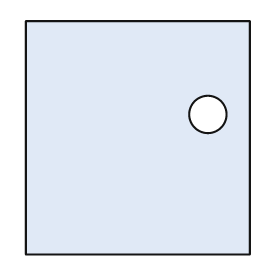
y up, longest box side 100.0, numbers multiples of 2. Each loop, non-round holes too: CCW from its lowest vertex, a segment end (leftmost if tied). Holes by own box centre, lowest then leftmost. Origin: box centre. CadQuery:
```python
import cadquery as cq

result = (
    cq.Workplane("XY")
    .moveTo(-48.0, -50.0)
    .lineTo(48.0, -50.0)
    .lineTo(48.0, 50.0)
    .lineTo(-48.0, 50.0)
    .close()
    .moveTo(30.0, 10.0)
    .circle(8.0)
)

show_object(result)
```